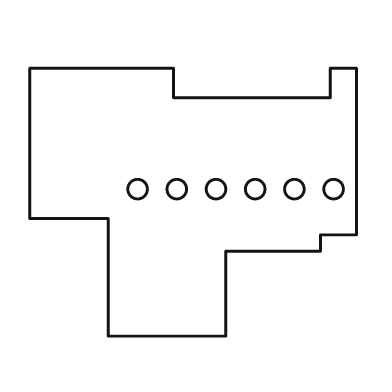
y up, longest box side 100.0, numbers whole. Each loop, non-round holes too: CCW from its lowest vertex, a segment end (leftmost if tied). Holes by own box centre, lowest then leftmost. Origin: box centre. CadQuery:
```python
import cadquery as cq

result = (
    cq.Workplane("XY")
    .moveTo(-26.0, -41.0)
    .lineTo(10.0, -41.0)
    .lineTo(10.0, -15.0)
    .lineTo(39.0, -15.0)
    .lineTo(39.0, -10.0)
    .lineTo(50.0, -10.0)
    .lineTo(50.0, 41.0)
    .lineTo(42.0, 41.0)
    .lineTo(42.0, 32.0)
    .lineTo(-6.0, 32.0)
    .lineTo(-6.0, 41.0)
    .lineTo(-50.0, 41.0)
    .lineTo(-50.0, -5.0)
    .lineTo(-26.0, -5.0)
    .close()
    .moveTo(-17.0, 4.0)
    .circle(3.0)
    .moveTo(-5.0, 4.0)
    .circle(3.0)
    .moveTo(7.0, 4.0)
    .circle(3.0)
    .moveTo(19.0, 4.0)
    .circle(3.0)
    .moveTo(31.0, 4.0)
    .circle(3.0)
    .moveTo(43.0, 4.0)
    .circle(3.0)
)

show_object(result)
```